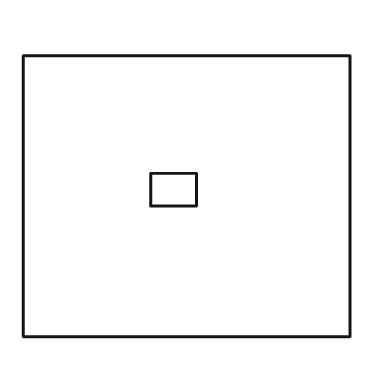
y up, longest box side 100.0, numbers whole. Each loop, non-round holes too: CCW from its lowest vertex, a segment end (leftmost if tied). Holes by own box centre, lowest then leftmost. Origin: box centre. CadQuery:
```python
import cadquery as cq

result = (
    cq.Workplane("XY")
    .moveTo(-50.0, -43.0)
    .lineTo(50.0, -43.0)
    .lineTo(50.0, 43.0)
    .lineTo(-50.0, 43.0)
    .close()
    .moveTo(-11.0, -3.0)
    .lineTo(3.0, -3.0)
    .lineTo(3.0, 7.0)
    .lineTo(-11.0, 7.0)
    .close()
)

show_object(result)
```